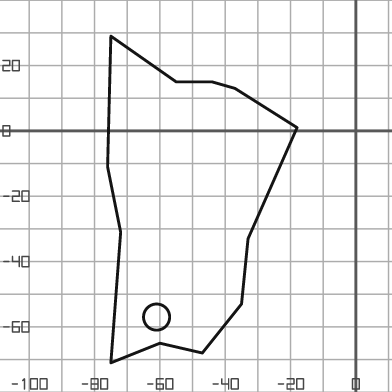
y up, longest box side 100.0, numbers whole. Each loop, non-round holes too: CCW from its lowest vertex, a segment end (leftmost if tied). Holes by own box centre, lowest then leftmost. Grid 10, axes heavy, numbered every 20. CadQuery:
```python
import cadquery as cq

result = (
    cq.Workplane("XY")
    .moveTo(-75.0, -71.0)
    .lineTo(-60.0, -65.0)
    .lineTo(-47.0, -68.0)
    .lineTo(-35.0, -53.0)
    .lineTo(-33.0, -33.0)
    .lineTo(-18.0, 1.0)
    .lineTo(-37.0, 13.0)
    .lineTo(-44.0, 15.0)
    .lineTo(-55.0, 15.0)
    .lineTo(-75.0, 29.0)
    .lineTo(-76.0, -11.0)
    .lineTo(-72.0, -31.0)
    .close()
    .moveTo(-61.0, -57.0)
    .circle(4.0)
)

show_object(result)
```